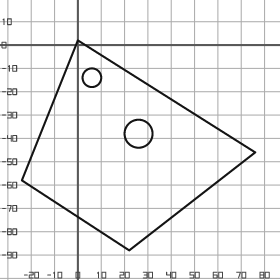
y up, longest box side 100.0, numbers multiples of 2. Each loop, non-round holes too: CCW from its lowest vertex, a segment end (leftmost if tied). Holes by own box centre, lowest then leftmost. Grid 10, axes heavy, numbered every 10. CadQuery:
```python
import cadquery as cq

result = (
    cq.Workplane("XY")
    .moveTo(22.0, -88.0)
    .lineTo(76.0, -46.0)
    .lineTo(0.0, 2.0)
    .lineTo(-24.0, -58.0)
    .close()
    .moveTo(26.0, -38.0)
    .circle(6.0)
    .moveTo(6.0, -14.0)
    .circle(4.0)
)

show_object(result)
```